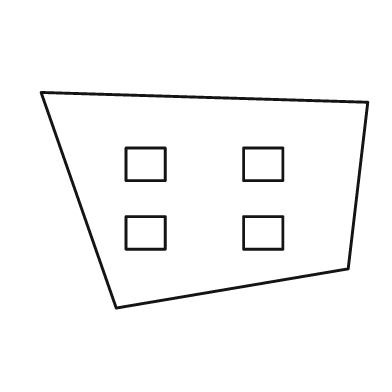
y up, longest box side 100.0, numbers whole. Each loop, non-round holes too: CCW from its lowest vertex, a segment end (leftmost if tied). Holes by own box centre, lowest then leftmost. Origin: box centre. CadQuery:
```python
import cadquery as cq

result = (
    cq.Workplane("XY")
    .moveTo(-27.0, -33.0)
    .lineTo(44.0, -21.0)
    .lineTo(50.0, 30.0)
    .lineTo(-50.0, 33.0)
    .close()
    .moveTo(-24.0, -15.0)
    .lineTo(-12.0, -15.0)
    .lineTo(-12.0, -5.0)
    .lineTo(-24.0, -5.0)
    .close()
    .moveTo(12.0, -15.0)
    .lineTo(24.0, -15.0)
    .lineTo(24.0, -5.0)
    .lineTo(12.0, -5.0)
    .close()
    .moveTo(-24.0, 6.0)
    .lineTo(-12.0, 6.0)
    .lineTo(-12.0, 16.0)
    .lineTo(-24.0, 16.0)
    .close()
    .moveTo(12.0, 6.0)
    .lineTo(24.0, 6.0)
    .lineTo(24.0, 16.0)
    .lineTo(12.0, 16.0)
    .close()
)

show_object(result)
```